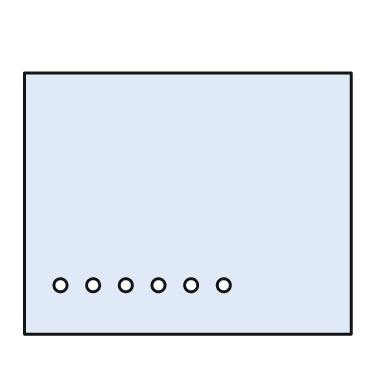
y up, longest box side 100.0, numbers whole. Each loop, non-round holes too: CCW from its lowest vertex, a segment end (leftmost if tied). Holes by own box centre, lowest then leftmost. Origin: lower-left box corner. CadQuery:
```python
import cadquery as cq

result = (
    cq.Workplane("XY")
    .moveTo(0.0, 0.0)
    .lineTo(100.0, 0.0)
    .lineTo(100.0, 80.0)
    .lineTo(0.0, 80.0)
    .close()
    .moveTo(11.0, 15.0)
    .circle(2.0)
    .moveTo(21.0, 15.0)
    .circle(2.0)
    .moveTo(31.0, 15.0)
    .circle(2.0)
    .moveTo(41.0, 15.0)
    .circle(2.0)
    .moveTo(51.0, 15.0)
    .circle(2.0)
    .moveTo(61.0, 15.0)
    .circle(2.0)
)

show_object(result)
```